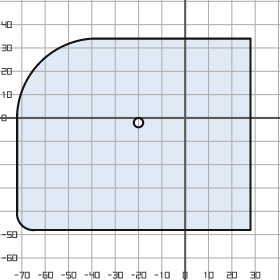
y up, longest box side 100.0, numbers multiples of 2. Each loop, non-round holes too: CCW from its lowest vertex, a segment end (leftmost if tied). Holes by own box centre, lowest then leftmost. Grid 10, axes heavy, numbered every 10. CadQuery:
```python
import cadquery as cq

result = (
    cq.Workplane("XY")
    .moveTo(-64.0, -48.0)
    .lineTo(28.0, -48.0)
    .lineTo(28.0, 34.0)
    .lineTo(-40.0, 34.0)
    .threePointArc((-62.0, 24.0), (-72.0, 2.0))
    .lineTo(-72.0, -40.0)
    .threePointArc((-70.0, -46.0), (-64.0, -48.0))
    .close()
    .moveTo(-20.0, -2.0)
    .circle(2.0)
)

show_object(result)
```